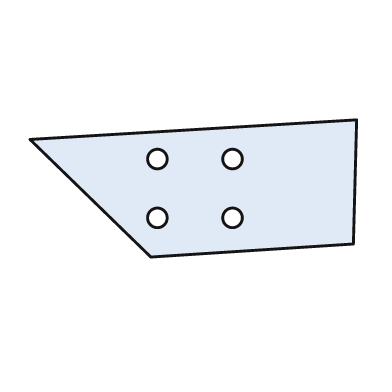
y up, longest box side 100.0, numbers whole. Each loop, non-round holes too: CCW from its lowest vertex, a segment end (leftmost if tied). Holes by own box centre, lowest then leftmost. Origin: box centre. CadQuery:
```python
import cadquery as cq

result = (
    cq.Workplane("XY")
    .moveTo(-13.0, -21.0)
    .lineTo(49.0, -17.0)
    .lineTo(50.0, 21.0)
    .lineTo(-50.0, 15.0)
    .close()
    .moveTo(-11.0, -9.0)
    .circle(3.0)
    .moveTo(12.0, -9.0)
    .circle(3.0)
    .moveTo(-11.0, 9.0)
    .circle(3.0)
    .moveTo(12.0, 9.0)
    .circle(3.0)
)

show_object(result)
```